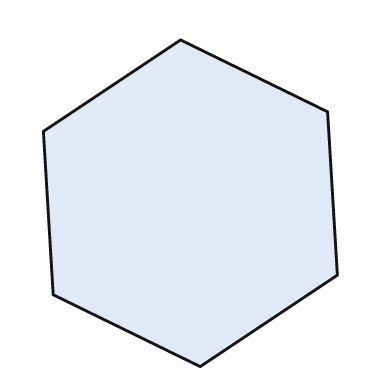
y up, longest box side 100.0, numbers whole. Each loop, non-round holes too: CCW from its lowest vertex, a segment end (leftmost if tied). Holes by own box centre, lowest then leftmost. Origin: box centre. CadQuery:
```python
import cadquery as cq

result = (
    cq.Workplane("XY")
    .moveTo(3.0, -50.0)
    .lineTo(45.0, -22.0)
    .lineTo(42.0, 28.0)
    .lineTo(-3.0, 50.0)
    .lineTo(-45.0, 22.0)
    .lineTo(-42.0, -28.0)
    .close()
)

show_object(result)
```